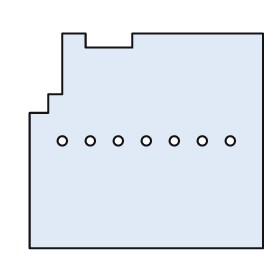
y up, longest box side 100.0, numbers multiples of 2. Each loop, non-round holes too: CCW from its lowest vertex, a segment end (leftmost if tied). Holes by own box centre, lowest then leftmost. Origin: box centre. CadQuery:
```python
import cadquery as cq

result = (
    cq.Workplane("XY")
    .moveTo(-50.0, -46.0)
    .lineTo(50.0, -46.0)
    .lineTo(50.0, 46.0)
    .lineTo(-6.0, 46.0)
    .lineTo(-6.0, 40.0)
    .lineTo(-26.0, 40.0)
    .lineTo(-26.0, 46.0)
    .lineTo(-36.0, 46.0)
    .lineTo(-36.0, 20.0)
    .lineTo(-42.0, 20.0)
    .lineTo(-42.0, 12.0)
    .lineTo(-50.0, 12.0)
    .close()
    .moveTo(-36.0, 0.0)
    .circle(2.0)
    .moveTo(-24.0, 0.0)
    .circle(2.0)
    .moveTo(-12.0, 0.0)
    .circle(2.0)
    .moveTo(0.0, 0.0)
    .circle(2.0)
    .moveTo(12.0, 0.0)
    .circle(2.0)
    .moveTo(24.0, 0.0)
    .circle(2.0)
    .moveTo(36.0, 0.0)
    .circle(2.0)
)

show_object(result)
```